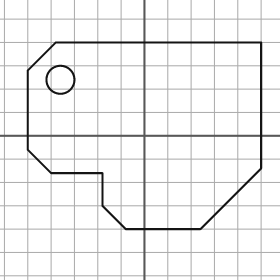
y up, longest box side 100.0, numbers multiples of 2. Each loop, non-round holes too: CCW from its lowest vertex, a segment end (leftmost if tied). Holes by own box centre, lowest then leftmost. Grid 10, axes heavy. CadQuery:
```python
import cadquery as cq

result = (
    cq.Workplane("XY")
    .moveTo(-8.0, -40.0)
    .lineTo(24.0, -40.0)
    .lineTo(50.0, -14.0)
    .lineTo(50.0, 40.0)
    .lineTo(-38.0, 40.0)
    .lineTo(-50.0, 28.0)
    .lineTo(-50.0, -6.0)
    .lineTo(-40.0, -16.0)
    .lineTo(-18.0, -16.0)
    .lineTo(-18.0, -30.0)
    .close()
    .moveTo(-36.0, 24.0)
    .circle(6.0)
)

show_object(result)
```